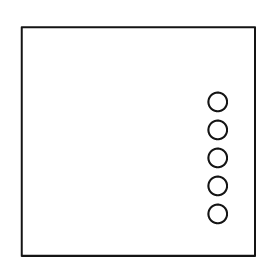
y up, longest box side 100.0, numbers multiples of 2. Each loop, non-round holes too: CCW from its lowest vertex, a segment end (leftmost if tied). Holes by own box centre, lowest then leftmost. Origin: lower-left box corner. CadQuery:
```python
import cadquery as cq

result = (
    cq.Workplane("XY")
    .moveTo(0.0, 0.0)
    .lineTo(100.0, 0.0)
    .lineTo(100.0, 98.0)
    .lineTo(0.0, 98.0)
    .close()
    .moveTo(84.0, 18.0)
    .circle(4.0)
    .moveTo(84.0, 30.0)
    .circle(4.0)
    .moveTo(84.0, 42.0)
    .circle(4.0)
    .moveTo(84.0, 54.0)
    .circle(4.0)
    .moveTo(84.0, 66.0)
    .circle(4.0)
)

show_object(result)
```